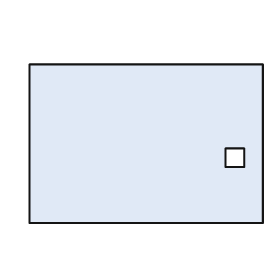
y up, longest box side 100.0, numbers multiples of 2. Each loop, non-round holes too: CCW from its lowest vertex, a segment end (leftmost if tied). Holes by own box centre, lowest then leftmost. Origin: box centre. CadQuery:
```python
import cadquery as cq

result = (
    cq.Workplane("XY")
    .moveTo(-50.0, -34.0)
    .lineTo(50.0, -34.0)
    .lineTo(50.0, 34.0)
    .lineTo(-50.0, 34.0)
    .close()
    .moveTo(34.0, -10.0)
    .lineTo(42.0, -10.0)
    .lineTo(42.0, -2.0)
    .lineTo(34.0, -2.0)
    .close()
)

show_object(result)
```